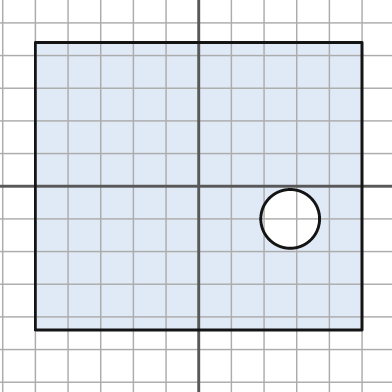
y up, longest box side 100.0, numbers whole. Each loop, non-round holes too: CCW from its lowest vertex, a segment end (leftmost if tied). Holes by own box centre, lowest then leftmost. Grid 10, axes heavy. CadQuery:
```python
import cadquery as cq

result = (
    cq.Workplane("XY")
    .moveTo(-50.0, -44.0)
    .lineTo(50.0, -44.0)
    .lineTo(50.0, 44.0)
    .lineTo(-50.0, 44.0)
    .close()
    .moveTo(28.0, -10.0)
    .circle(9.0)
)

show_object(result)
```